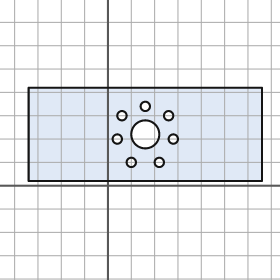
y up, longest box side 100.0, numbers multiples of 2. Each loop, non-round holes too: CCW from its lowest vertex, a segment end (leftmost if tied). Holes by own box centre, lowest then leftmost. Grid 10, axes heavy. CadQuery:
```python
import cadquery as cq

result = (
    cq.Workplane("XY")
    .moveTo(-34.0, 2.0)
    .lineTo(66.0, 2.0)
    .lineTo(66.0, 42.0)
    .lineTo(-34.0, 42.0)
    .close()
    .moveTo(10.0, 10.0)
    .circle(2.0)
    .moveTo(22.0, 10.0)
    .circle(2.0)
    .moveTo(4.0, 20.0)
    .circle(2.0)
    .moveTo(28.0, 20.0)
    .circle(2.0)
    .moveTo(16.0, 22.0)
    .circle(6.0)
    .moveTo(6.0, 30.0)
    .circle(2.0)
    .moveTo(26.0, 30.0)
    .circle(2.0)
    .moveTo(16.0, 34.0)
    .circle(2.0)
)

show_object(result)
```